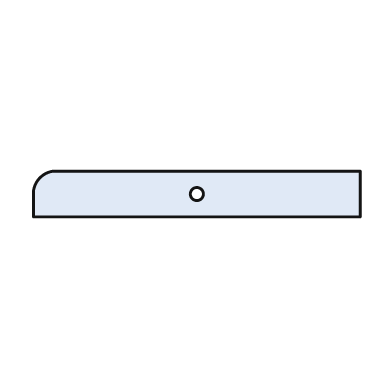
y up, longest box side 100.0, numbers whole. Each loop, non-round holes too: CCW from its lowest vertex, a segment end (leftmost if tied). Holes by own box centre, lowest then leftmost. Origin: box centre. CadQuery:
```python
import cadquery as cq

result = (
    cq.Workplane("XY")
    .moveTo(-50.0, -7.0)
    .lineTo(50.0, -7.0)
    .lineTo(50.0, 7.0)
    .lineTo(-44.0, 7.0)
    .threePointArc((-48.0, 5.0), (-50.0, 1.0))
    .close()
    .moveTo(0.0, 0.0)
    .circle(2.0)
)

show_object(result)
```